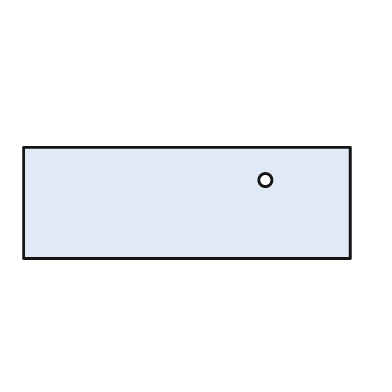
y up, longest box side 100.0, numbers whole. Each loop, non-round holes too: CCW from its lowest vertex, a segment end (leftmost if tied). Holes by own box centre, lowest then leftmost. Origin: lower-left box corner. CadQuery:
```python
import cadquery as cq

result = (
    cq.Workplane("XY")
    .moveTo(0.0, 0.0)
    .lineTo(100.0, 0.0)
    .lineTo(100.0, 34.0)
    .lineTo(0.0, 34.0)
    .close()
    .moveTo(74.0, 24.0)
    .circle(2.0)
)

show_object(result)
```